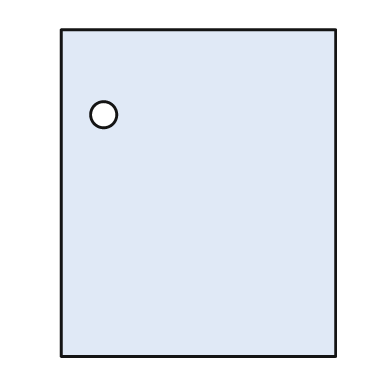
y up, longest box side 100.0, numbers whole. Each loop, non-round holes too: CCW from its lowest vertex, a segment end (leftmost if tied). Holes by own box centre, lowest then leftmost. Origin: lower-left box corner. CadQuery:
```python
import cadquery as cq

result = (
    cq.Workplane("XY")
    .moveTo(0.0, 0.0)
    .lineTo(84.0, 0.0)
    .lineTo(84.0, 100.0)
    .lineTo(0.0, 100.0)
    .close()
    .moveTo(13.0, 74.0)
    .circle(4.0)
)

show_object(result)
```